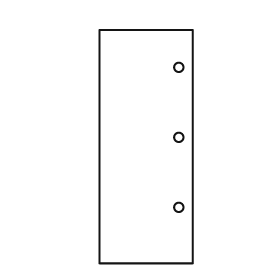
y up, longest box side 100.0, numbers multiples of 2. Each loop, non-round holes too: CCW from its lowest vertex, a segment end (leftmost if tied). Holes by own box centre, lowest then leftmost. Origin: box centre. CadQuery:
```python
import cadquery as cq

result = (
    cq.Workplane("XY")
    .moveTo(-20.0, -50.0)
    .lineTo(20.0, -50.0)
    .lineTo(20.0, 50.0)
    .lineTo(-20.0, 50.0)
    .close()
    .moveTo(14.0, -26.0)
    .circle(2.0)
    .moveTo(14.0, 4.0)
    .circle(2.0)
    .moveTo(14.0, 34.0)
    .circle(2.0)
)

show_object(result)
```